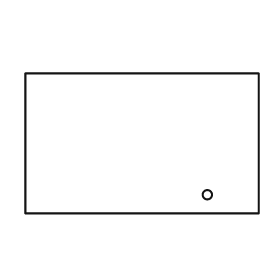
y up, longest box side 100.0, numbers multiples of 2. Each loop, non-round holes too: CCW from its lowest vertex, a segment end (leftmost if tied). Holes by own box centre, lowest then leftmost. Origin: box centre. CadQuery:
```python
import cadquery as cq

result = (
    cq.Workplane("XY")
    .moveTo(-50.0, -30.0)
    .lineTo(50.0, -30.0)
    .lineTo(50.0, 30.0)
    .lineTo(-50.0, 30.0)
    .close()
    .moveTo(28.0, -22.0)
    .circle(2.0)
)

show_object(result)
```